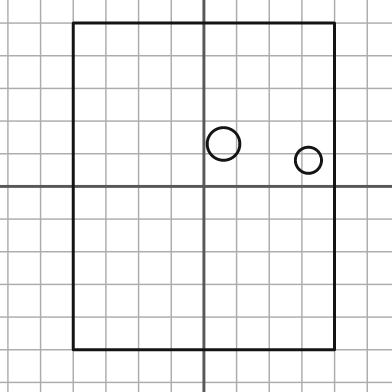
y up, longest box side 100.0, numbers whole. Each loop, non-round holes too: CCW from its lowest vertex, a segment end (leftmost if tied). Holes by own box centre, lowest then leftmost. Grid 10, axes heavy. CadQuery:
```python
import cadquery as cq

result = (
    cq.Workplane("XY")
    .moveTo(-40.0, -50.0)
    .lineTo(40.0, -50.0)
    .lineTo(40.0, 50.0)
    .lineTo(-40.0, 50.0)
    .close()
    .moveTo(32.0, 8.0)
    .circle(4.0)
    .moveTo(6.0, 13.0)
    .circle(5.0)
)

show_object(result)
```